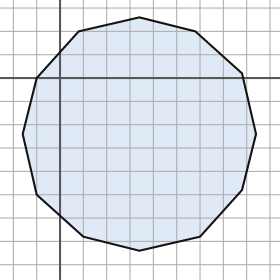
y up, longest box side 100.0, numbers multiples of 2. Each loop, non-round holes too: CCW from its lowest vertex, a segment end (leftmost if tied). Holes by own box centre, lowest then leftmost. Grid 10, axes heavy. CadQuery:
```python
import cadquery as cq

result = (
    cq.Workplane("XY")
    .moveTo(34.0, -74.0)
    .lineTo(60.0, -68.0)
    .lineTo(78.0, -48.0)
    .lineTo(84.0, -24.0)
    .lineTo(78.0, 2.0)
    .lineTo(58.0, 20.0)
    .lineTo(34.0, 26.0)
    .lineTo(8.0, 20.0)
    .lineTo(-10.0, 0.0)
    .lineTo(-16.0, -24.0)
    .lineTo(-10.0, -50.0)
    .lineTo(10.0, -68.0)
    .close()
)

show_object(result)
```